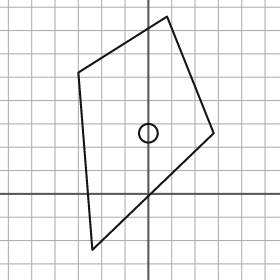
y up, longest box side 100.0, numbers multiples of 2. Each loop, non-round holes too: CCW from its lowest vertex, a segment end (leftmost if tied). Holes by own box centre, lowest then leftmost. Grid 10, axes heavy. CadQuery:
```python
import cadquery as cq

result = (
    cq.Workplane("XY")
    .moveTo(-24.0, -24.0)
    .lineTo(28.0, 26.0)
    .lineTo(8.0, 76.0)
    .lineTo(-30.0, 52.0)
    .close()
    .moveTo(0.0, 26.0)
    .circle(4.0)
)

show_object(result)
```